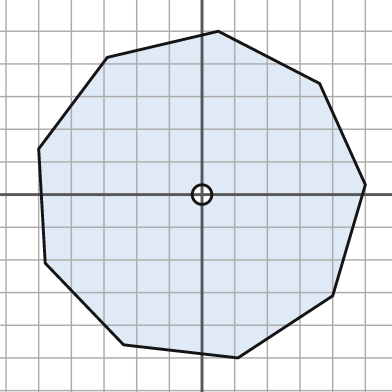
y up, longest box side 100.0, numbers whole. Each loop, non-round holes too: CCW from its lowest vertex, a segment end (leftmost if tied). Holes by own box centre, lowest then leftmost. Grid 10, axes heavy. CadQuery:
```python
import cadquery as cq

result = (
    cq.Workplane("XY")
    .moveTo(11.0, -50.0)
    .lineTo(40.0, -31.0)
    .lineTo(50.0, 3.0)
    .lineTo(36.0, 34.0)
    .lineTo(5.0, 50.0)
    .lineTo(-29.0, 42.0)
    .lineTo(-50.0, 14.0)
    .lineTo(-48.0, -21.0)
    .lineTo(-24.0, -46.0)
    .close()
    .moveTo(0.0, 0.0)
    .circle(3.0)
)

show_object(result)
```